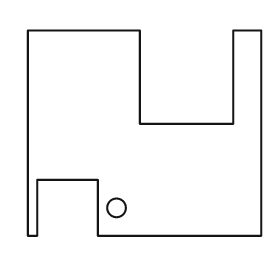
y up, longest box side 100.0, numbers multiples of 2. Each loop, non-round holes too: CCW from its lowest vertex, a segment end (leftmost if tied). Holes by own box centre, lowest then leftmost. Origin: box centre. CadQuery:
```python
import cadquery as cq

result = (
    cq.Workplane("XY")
    .moveTo(-50.0, -44.0)
    .lineTo(-46.0, -44.0)
    .lineTo(-46.0, -20.0)
    .lineTo(-20.0, -20.0)
    .lineTo(-20.0, -44.0)
    .lineTo(50.0, -44.0)
    .lineTo(50.0, 44.0)
    .lineTo(38.0, 44.0)
    .lineTo(38.0, 4.0)
    .lineTo(-2.0, 4.0)
    .lineTo(-2.0, 44.0)
    .lineTo(-50.0, 44.0)
    .close()
    .moveTo(-12.0, -32.0)
    .circle(4.0)
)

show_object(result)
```